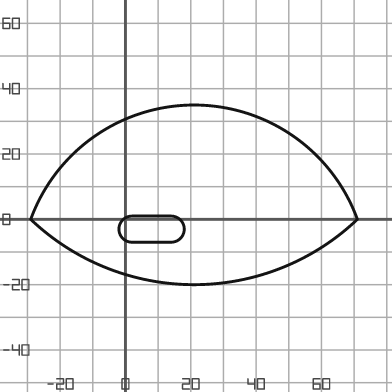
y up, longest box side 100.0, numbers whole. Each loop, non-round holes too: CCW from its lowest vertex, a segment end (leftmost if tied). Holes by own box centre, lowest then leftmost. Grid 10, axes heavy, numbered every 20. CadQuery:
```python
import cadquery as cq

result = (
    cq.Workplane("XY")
    .moveTo(-29.0, 0.0)
    .threePointArc((21.0, -20.0), (71.0, 0.0))
    .threePointArc((21.0, 35.0), (-29.0, 0.0))
    .close()
    .moveTo(2.0, -7.0)
    .lineTo(14.0, -7.0)
    .threePointArc((18.0, -3.0), (14.0, 1.0))
    .lineTo(2.0, 1.0)
    .threePointArc((-2.0, -3.0), (2.0, -7.0))
    .close()
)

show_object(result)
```